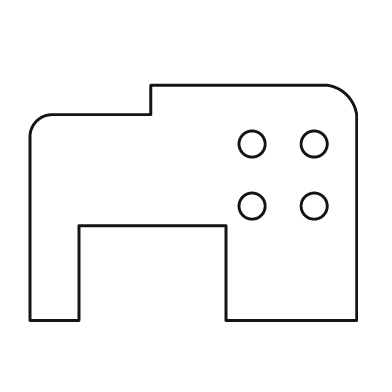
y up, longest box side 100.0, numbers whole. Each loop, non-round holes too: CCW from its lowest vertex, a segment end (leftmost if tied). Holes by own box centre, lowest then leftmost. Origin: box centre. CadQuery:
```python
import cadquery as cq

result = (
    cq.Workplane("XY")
    .moveTo(-50.0, -36.0)
    .lineTo(-35.0, -36.0)
    .lineTo(-35.0, -7.0)
    .lineTo(10.0, -7.0)
    .lineTo(10.0, -36.0)
    .lineTo(50.0, -36.0)
    .lineTo(50.0, 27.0)
    .threePointArc((47.0, 33.0), (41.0, 36.0))
    .lineTo(-13.0, 36.0)
    .lineTo(-13.0, 27.0)
    .lineTo(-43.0, 27.0)
    .threePointArc((-48.0, 25.0), (-50.0, 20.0))
    .close()
    .moveTo(18.0, -1.0)
    .circle(4.0)
    .moveTo(37.0, -1.0)
    .circle(4.0)
    .moveTo(18.0, 18.0)
    .circle(4.0)
    .moveTo(37.0, 18.0)
    .circle(4.0)
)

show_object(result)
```